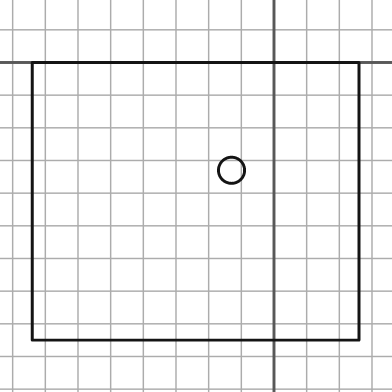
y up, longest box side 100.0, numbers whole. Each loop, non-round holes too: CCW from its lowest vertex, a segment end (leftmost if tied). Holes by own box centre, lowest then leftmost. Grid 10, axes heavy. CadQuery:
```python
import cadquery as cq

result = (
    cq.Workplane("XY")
    .moveTo(-74.0, -85.0)
    .lineTo(26.0, -85.0)
    .lineTo(26.0, 0.0)
    .lineTo(-74.0, 0.0)
    .close()
    .moveTo(-13.0, -33.0)
    .circle(4.0)
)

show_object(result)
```